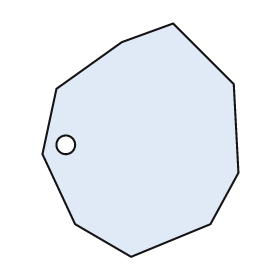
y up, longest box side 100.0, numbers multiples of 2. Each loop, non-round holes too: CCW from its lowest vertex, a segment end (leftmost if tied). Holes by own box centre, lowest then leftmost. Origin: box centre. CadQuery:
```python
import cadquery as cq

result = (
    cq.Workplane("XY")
    .moveTo(-4.0, -50.0)
    .lineTo(30.0, -36.0)
    .lineTo(42.0, -14.0)
    .lineTo(40.0, 24.0)
    .lineTo(14.0, 50.0)
    .lineTo(-8.0, 42.0)
    .lineTo(-36.0, 22.0)
    .lineTo(-42.0, -6.0)
    .lineTo(-28.0, -36.0)
    .close()
    .moveTo(-32.0, -2.0)
    .circle(4.0)
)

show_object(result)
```